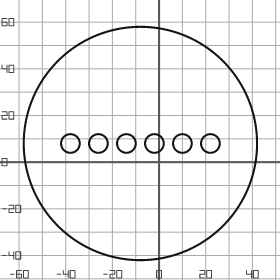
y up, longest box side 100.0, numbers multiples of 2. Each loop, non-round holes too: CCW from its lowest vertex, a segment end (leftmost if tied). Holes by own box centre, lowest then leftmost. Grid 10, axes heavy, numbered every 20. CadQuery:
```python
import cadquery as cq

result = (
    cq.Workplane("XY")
    .moveTo(-8.0, 8.0)
    .circle(50.0)
    .moveTo(-38.0, 8.0)
    .circle(4.0)
    .moveTo(-26.0, 8.0)
    .circle(4.0)
    .moveTo(-14.0, 8.0)
    .circle(4.0)
    .moveTo(-2.0, 8.0)
    .circle(4.0)
    .moveTo(10.0, 8.0)
    .circle(4.0)
    .moveTo(22.0, 8.0)
    .circle(4.0)
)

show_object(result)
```